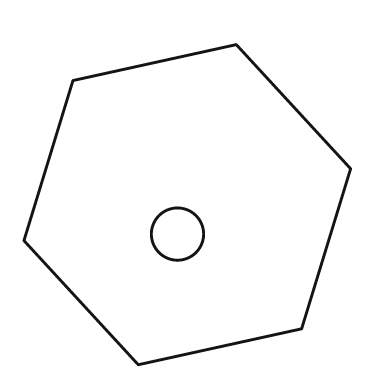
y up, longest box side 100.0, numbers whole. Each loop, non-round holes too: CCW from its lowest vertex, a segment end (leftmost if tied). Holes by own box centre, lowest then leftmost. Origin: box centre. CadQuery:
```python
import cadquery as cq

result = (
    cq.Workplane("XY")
    .moveTo(-15.0, -49.0)
    .lineTo(35.0, -38.0)
    .lineTo(50.0, 11.0)
    .lineTo(15.0, 49.0)
    .lineTo(-35.0, 38.0)
    .lineTo(-50.0, -11.0)
    .close()
    .moveTo(-3.0, -9.0)
    .circle(8.0)
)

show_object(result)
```